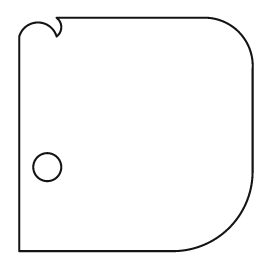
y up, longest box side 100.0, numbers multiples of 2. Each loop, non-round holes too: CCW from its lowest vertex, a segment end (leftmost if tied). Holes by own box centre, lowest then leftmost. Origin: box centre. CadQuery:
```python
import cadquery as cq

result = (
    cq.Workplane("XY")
    .moveTo(-50.0, -50.0)
    .lineTo(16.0, -50.0)
    .threePointArc((40.0, -40.0), (50.0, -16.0))
    .lineTo(50.0, 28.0)
    .threePointArc((44.0, 44.0), (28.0, 50.0))
    .lineTo(-34.0, 50.0)
    .threePointArc((-32.0, 46.0), (-34.0, 42.0))
    .threePointArc((-42.0, 48.0), (-50.0, 42.0))
    .close()
    .moveTo(-38.0, -14.0)
    .circle(6.0)
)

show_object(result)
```